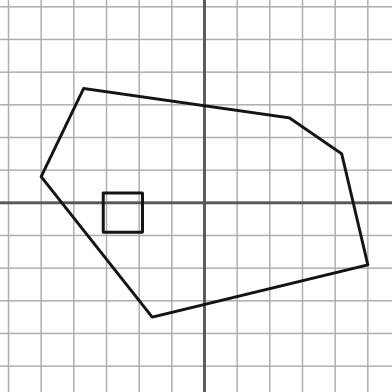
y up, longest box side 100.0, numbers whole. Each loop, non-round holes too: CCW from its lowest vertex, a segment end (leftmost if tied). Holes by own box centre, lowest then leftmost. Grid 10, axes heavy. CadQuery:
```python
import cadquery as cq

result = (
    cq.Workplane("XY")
    .moveTo(-16.0, -35.0)
    .lineTo(50.0, -19.0)
    .lineTo(42.0, 15.0)
    .lineTo(26.0, 26.0)
    .lineTo(-37.0, 35.0)
    .lineTo(-50.0, 8.0)
    .close()
    .moveTo(-31.0, -9.0)
    .lineTo(-19.0, -9.0)
    .lineTo(-19.0, 3.0)
    .lineTo(-31.0, 3.0)
    .close()
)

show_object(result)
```